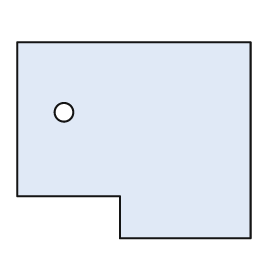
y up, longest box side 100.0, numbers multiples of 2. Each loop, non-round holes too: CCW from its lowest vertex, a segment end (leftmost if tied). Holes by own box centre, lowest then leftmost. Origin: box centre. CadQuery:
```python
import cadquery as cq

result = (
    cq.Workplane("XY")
    .moveTo(-6.0, -42.0)
    .lineTo(50.0, -42.0)
    .lineTo(50.0, 42.0)
    .lineTo(-50.0, 42.0)
    .lineTo(-50.0, -24.0)
    .lineTo(-6.0, -24.0)
    .close()
    .moveTo(-30.0, 12.0)
    .circle(4.0)
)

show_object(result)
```